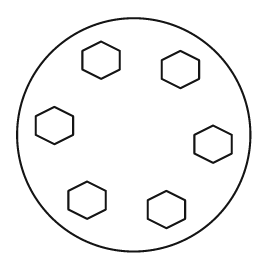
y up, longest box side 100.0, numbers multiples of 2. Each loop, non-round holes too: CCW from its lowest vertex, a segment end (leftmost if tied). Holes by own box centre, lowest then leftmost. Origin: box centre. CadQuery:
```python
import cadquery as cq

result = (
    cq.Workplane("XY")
    .moveTo(0.0, 0.0)
    .circle(50.0)
    .moveTo(14.0, -40.0)
    .lineTo(22.0, -36.0)
    .lineTo(22.0, -28.0)
    .lineTo(14.0, -24.0)
    .lineTo(6.0, -28.0)
    .lineTo(6.0, -36.0)
    .close()
    .moveTo(-20.0, -36.0)
    .lineTo(-12.0, -32.0)
    .lineTo(-12.0, -24.0)
    .lineTo(-20.0, -20.0)
    .lineTo(-28.0, -24.0)
    .lineTo(-28.0, -32.0)
    .close()
    .moveTo(34.0, -12.0)
    .lineTo(42.0, -8.0)
    .lineTo(42.0, 0.0)
    .lineTo(34.0, 4.0)
    .lineTo(26.0, 0.0)
    .lineTo(26.0, -8.0)
    .close()
    .moveTo(-34.0, -4.0)
    .lineTo(-26.0, 0.0)
    .lineTo(-26.0, 8.0)
    .lineTo(-34.0, 12.0)
    .lineTo(-42.0, 8.0)
    .lineTo(-42.0, 0.0)
    .close()
    .moveTo(20.0, 20.0)
    .lineTo(28.0, 24.0)
    .lineTo(28.0, 32.0)
    .lineTo(20.0, 36.0)
    .lineTo(12.0, 32.0)
    .lineTo(12.0, 24.0)
    .close()
    .moveTo(-14.0, 24.0)
    .lineTo(-6.0, 28.0)
    .lineTo(-6.0, 36.0)
    .lineTo(-14.0, 40.0)
    .lineTo(-22.0, 36.0)
    .lineTo(-22.0, 28.0)
    .close()
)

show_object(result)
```